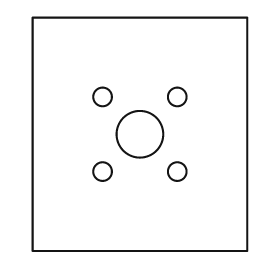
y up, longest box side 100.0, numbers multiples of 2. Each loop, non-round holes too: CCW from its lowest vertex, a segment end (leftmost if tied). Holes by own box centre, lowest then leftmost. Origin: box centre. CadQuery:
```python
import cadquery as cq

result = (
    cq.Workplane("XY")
    .moveTo(-46.0, -50.0)
    .lineTo(46.0, -50.0)
    .lineTo(46.0, 50.0)
    .lineTo(-46.0, 50.0)
    .close()
    .moveTo(-16.0, -16.0)
    .circle(4.0)
    .moveTo(16.0, -16.0)
    .circle(4.0)
    .moveTo(0.0, 0.0)
    .circle(10.0)
    .moveTo(-16.0, 16.0)
    .circle(4.0)
    .moveTo(16.0, 16.0)
    .circle(4.0)
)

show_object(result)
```